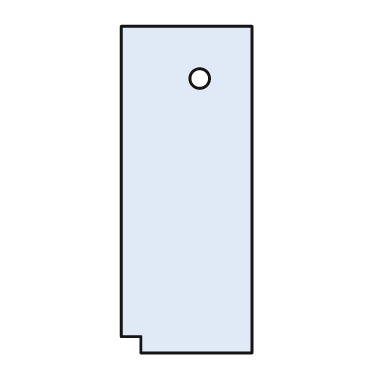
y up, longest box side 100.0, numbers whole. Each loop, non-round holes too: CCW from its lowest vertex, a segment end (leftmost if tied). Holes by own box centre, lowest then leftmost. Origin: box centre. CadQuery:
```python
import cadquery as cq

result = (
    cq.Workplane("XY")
    .moveTo(-14.0, -50.0)
    .lineTo(20.0, -50.0)
    .lineTo(20.0, 50.0)
    .lineTo(-20.0, 50.0)
    .lineTo(-20.0, -45.0)
    .lineTo(-14.0, -45.0)
    .close()
    .moveTo(4.0, 34.0)
    .circle(3.0)
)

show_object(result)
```